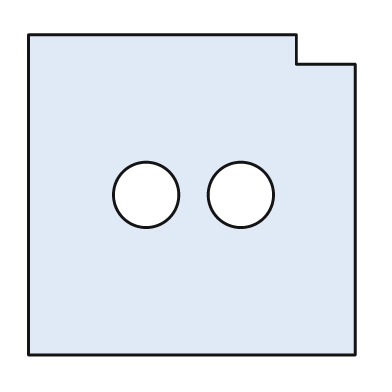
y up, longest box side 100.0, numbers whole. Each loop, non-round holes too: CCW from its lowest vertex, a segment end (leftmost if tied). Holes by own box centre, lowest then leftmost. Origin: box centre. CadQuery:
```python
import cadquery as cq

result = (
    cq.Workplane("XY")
    .moveTo(-50.0, -49.0)
    .lineTo(50.0, -49.0)
    .lineTo(50.0, 40.0)
    .lineTo(32.0, 40.0)
    .lineTo(32.0, 49.0)
    .lineTo(-50.0, 49.0)
    .close()
    .moveTo(-14.0, 0.0)
    .circle(10.0)
    .moveTo(15.0, 0.0)
    .circle(10.0)
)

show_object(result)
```